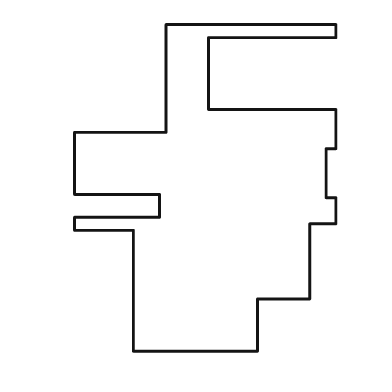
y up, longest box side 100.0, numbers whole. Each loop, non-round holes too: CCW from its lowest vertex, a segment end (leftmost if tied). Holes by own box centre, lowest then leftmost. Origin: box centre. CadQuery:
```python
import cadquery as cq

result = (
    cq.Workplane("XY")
    .moveTo(-22.0, -50.0)
    .lineTo(16.0, -50.0)
    .lineTo(16.0, -34.0)
    .lineTo(32.0, -34.0)
    .lineTo(32.0, -11.0)
    .lineTo(40.0, -11.0)
    .lineTo(40.0, -3.0)
    .lineTo(37.0, -3.0)
    .lineTo(37.0, 12.0)
    .lineTo(40.0, 12.0)
    .lineTo(40.0, 24.0)
    .lineTo(1.0, 24.0)
    .lineTo(1.0, 46.0)
    .lineTo(40.0, 46.0)
    .lineTo(40.0, 50.0)
    .lineTo(-12.0, 50.0)
    .lineTo(-12.0, 17.0)
    .lineTo(-40.0, 17.0)
    .lineTo(-40.0, -2.0)
    .lineTo(-14.0, -2.0)
    .lineTo(-14.0, -9.0)
    .lineTo(-40.0, -9.0)
    .lineTo(-40.0, -13.0)
    .lineTo(-22.0, -13.0)
    .close()
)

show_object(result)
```